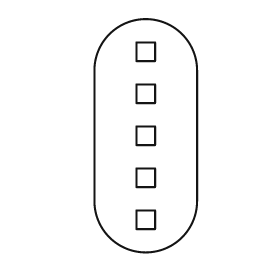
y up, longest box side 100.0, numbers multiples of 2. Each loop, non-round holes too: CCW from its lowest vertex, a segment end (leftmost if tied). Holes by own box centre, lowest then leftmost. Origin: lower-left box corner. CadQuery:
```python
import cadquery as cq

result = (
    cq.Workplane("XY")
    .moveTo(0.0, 22.0)
    .threePointArc((22.0, 0.0), (44.0, 22.0))
    .lineTo(44.0, 78.0)
    .threePointArc((22.0, 100.0), (0.0, 78.0))
    .close()
    .moveTo(18.0, 10.0)
    .lineTo(26.0, 10.0)
    .lineTo(26.0, 18.0)
    .lineTo(18.0, 18.0)
    .close()
    .moveTo(18.0, 28.0)
    .lineTo(26.0, 28.0)
    .lineTo(26.0, 36.0)
    .lineTo(18.0, 36.0)
    .close()
    .moveTo(18.0, 46.0)
    .lineTo(26.0, 46.0)
    .lineTo(26.0, 54.0)
    .lineTo(18.0, 54.0)
    .close()
    .moveTo(18.0, 64.0)
    .lineTo(26.0, 64.0)
    .lineTo(26.0, 72.0)
    .lineTo(18.0, 72.0)
    .close()
    .moveTo(18.0, 82.0)
    .lineTo(26.0, 82.0)
    .lineTo(26.0, 90.0)
    .lineTo(18.0, 90.0)
    .close()
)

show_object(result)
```